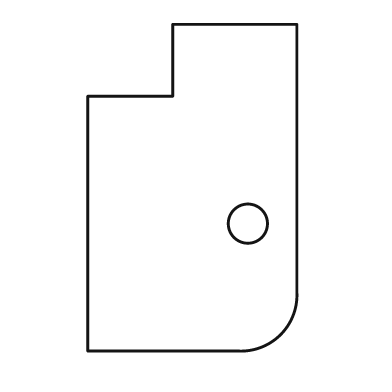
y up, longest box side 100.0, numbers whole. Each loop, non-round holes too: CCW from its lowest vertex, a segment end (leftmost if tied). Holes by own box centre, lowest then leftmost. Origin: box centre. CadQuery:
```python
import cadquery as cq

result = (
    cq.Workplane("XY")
    .moveTo(-32.0, -50.0)
    .lineTo(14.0, -50.0)
    .threePointArc((27.0, -45.0), (32.0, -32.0))
    .lineTo(32.0, 50.0)
    .lineTo(-6.0, 50.0)
    .lineTo(-6.0, 28.0)
    .lineTo(-32.0, 28.0)
    .close()
    .moveTo(17.0, -11.0)
    .circle(6.0)
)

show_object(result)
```